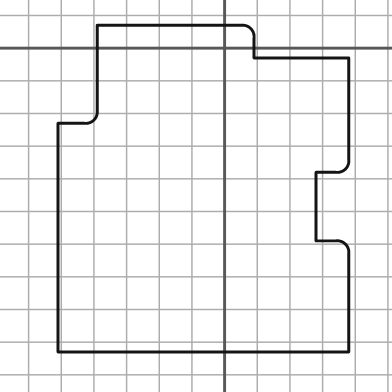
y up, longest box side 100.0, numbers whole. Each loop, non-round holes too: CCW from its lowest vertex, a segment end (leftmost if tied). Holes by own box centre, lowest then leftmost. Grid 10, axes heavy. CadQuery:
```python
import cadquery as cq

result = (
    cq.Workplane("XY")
    .moveTo(-51.0, -93.0)
    .lineTo(38.0, -93.0)
    .lineTo(38.0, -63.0)
    .threePointArc((37.0, -60.0), (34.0, -59.0))
    .lineTo(28.0, -59.0)
    .lineTo(28.0, -38.0)
    .lineTo(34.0, -38.0)
    .threePointArc((37.0, -37.0), (38.0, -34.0))
    .lineTo(38.0, -3.0)
    .lineTo(9.0, -3.0)
    .lineTo(9.0, 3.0)
    .threePointArc((8.0, 6.0), (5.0, 7.0))
    .lineTo(-39.0, 7.0)
    .lineTo(-39.0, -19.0)
    .threePointArc((-40.0, -22.0), (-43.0, -23.0))
    .lineTo(-51.0, -23.0)
    .close()
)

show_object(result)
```